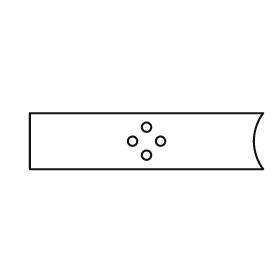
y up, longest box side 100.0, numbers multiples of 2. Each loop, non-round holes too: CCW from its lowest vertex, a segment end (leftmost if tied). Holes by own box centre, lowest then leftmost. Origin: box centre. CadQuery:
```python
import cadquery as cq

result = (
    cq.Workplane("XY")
    .moveTo(-50.0, -12.0)
    .lineTo(50.0, -12.0)
    .threePointArc((46.0, 0.0), (50.0, 12.0))
    .lineTo(-50.0, 12.0)
    .close()
    .moveTo(0.0, -6.0)
    .circle(2.0)
    .moveTo(-6.0, 0.0)
    .circle(2.0)
    .moveTo(6.0, 0.0)
    .circle(2.0)
    .moveTo(0.0, 6.0)
    .circle(2.0)
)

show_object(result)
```